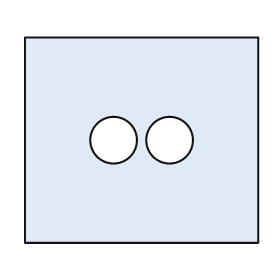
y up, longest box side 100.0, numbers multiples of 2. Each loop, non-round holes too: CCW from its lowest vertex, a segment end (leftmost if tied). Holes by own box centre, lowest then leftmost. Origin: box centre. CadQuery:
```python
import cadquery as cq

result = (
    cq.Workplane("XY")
    .moveTo(-50.0, -44.0)
    .lineTo(50.0, -44.0)
    .lineTo(50.0, 44.0)
    .lineTo(-50.0, 44.0)
    .close()
    .moveTo(-12.0, 0.0)
    .circle(10.0)
    .moveTo(12.0, 0.0)
    .circle(10.0)
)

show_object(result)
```